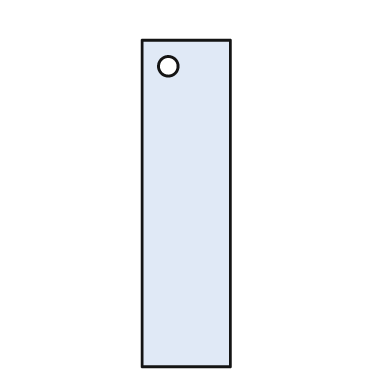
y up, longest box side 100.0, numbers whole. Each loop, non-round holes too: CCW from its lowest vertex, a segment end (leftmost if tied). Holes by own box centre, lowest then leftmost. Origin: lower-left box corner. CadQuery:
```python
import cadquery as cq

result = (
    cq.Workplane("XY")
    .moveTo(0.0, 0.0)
    .lineTo(27.0, 0.0)
    .lineTo(27.0, 100.0)
    .lineTo(0.0, 100.0)
    .close()
    .moveTo(8.0, 92.0)
    .circle(3.0)
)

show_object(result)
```